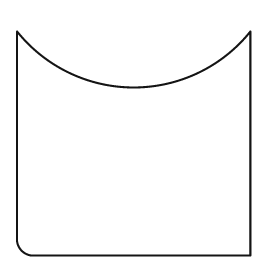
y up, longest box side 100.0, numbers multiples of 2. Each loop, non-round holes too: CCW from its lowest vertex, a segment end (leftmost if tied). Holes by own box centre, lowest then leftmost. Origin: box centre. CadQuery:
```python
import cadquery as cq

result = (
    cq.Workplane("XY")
    .moveTo(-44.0, -48.0)
    .lineTo(50.0, -48.0)
    .lineTo(50.0, 48.0)
    .threePointArc((0.0, 24.0), (-50.0, 48.0))
    .lineTo(-50.0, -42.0)
    .threePointArc((-48.0, -46.0), (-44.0, -48.0))
    .close()
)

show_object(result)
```